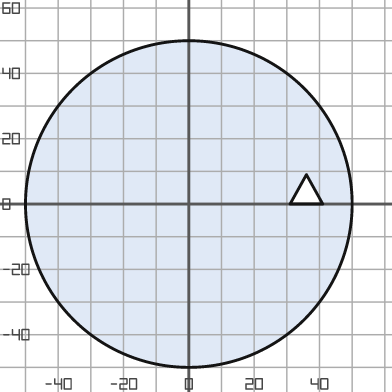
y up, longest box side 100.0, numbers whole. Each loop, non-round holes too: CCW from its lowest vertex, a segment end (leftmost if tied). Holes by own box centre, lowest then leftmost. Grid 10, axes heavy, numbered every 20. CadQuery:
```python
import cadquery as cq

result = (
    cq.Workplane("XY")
    .moveTo(0.0, 0.0)
    .circle(50.0)
    .moveTo(31.0, 0.0)
    .lineTo(41.0, 0.0)
    .lineTo(36.0, 9.0)
    .close()
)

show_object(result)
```